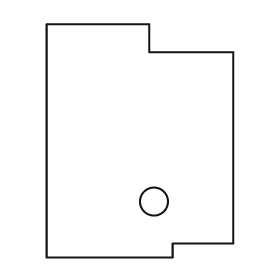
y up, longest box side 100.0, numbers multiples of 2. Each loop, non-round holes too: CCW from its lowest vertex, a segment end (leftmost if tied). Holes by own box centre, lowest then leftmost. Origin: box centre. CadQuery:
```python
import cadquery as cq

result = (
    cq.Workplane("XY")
    .moveTo(-40.0, -50.0)
    .lineTo(14.0, -50.0)
    .lineTo(14.0, -44.0)
    .lineTo(40.0, -44.0)
    .lineTo(40.0, 38.0)
    .lineTo(4.0, 38.0)
    .lineTo(4.0, 50.0)
    .lineTo(-40.0, 50.0)
    .close()
    .moveTo(6.0, -26.0)
    .circle(6.0)
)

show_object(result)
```